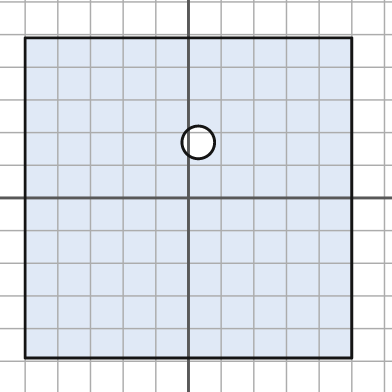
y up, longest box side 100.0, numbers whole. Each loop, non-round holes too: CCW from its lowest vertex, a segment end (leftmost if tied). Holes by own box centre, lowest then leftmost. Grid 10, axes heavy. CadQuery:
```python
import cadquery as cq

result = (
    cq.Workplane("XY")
    .moveTo(-50.0, -49.0)
    .lineTo(50.0, -49.0)
    .lineTo(50.0, 49.0)
    .lineTo(-50.0, 49.0)
    .close()
    .moveTo(3.0, 17.0)
    .circle(5.0)
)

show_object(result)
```